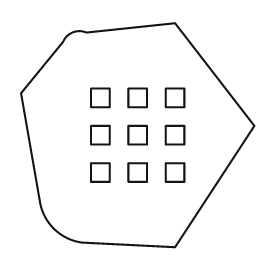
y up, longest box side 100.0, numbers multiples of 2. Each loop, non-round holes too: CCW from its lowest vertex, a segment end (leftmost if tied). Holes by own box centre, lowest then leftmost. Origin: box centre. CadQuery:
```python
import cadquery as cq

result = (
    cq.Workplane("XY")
    .moveTo(16.0, -48.0)
    .lineTo(50.0, 4.0)
    .lineTo(16.0, 48.0)
    .lineTo(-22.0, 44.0)
    .threePointArc((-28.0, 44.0), (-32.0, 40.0))
    .lineTo(-50.0, 18.0)
    .lineTo(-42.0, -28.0)
    .threePointArc((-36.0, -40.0), (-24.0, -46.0))
    .close()
    .moveTo(-20.0, -20.0)
    .lineTo(-12.0, -20.0)
    .lineTo(-12.0, -12.0)
    .lineTo(-20.0, -12.0)
    .close()
    .moveTo(-4.0, -20.0)
    .lineTo(4.0, -20.0)
    .lineTo(4.0, -12.0)
    .lineTo(-4.0, -12.0)
    .close()
    .moveTo(12.0, -20.0)
    .lineTo(20.0, -20.0)
    .lineTo(20.0, -12.0)
    .lineTo(12.0, -12.0)
    .close()
    .moveTo(-20.0, -4.0)
    .lineTo(-12.0, -4.0)
    .lineTo(-12.0, 4.0)
    .lineTo(-20.0, 4.0)
    .close()
    .moveTo(-4.0, -4.0)
    .lineTo(4.0, -4.0)
    .lineTo(4.0, 4.0)
    .lineTo(-4.0, 4.0)
    .close()
    .moveTo(12.0, -4.0)
    .lineTo(20.0, -4.0)
    .lineTo(20.0, 4.0)
    .lineTo(12.0, 4.0)
    .close()
    .moveTo(-20.0, 12.0)
    .lineTo(-12.0, 12.0)
    .lineTo(-12.0, 20.0)
    .lineTo(-20.0, 20.0)
    .close()
    .moveTo(-4.0, 12.0)
    .lineTo(4.0, 12.0)
    .lineTo(4.0, 20.0)
    .lineTo(-4.0, 20.0)
    .close()
    .moveTo(12.0, 12.0)
    .lineTo(20.0, 12.0)
    .lineTo(20.0, 20.0)
    .lineTo(12.0, 20.0)
    .close()
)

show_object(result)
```